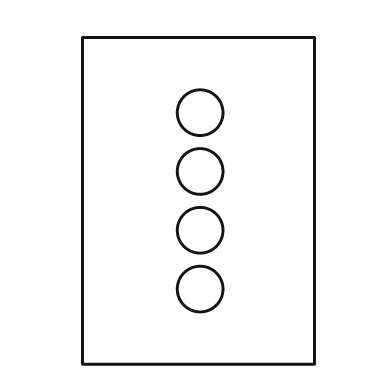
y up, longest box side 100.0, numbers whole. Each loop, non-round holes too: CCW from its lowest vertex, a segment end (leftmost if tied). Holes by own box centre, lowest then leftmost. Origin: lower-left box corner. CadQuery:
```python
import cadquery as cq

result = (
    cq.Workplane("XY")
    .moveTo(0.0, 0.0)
    .lineTo(71.0, 0.0)
    .lineTo(71.0, 100.0)
    .lineTo(0.0, 100.0)
    .close()
    .moveTo(36.0, 23.0)
    .circle(7.0)
    .moveTo(36.0, 41.0)
    .circle(7.0)
    .moveTo(36.0, 59.0)
    .circle(7.0)
    .moveTo(36.0, 77.0)
    .circle(7.0)
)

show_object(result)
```